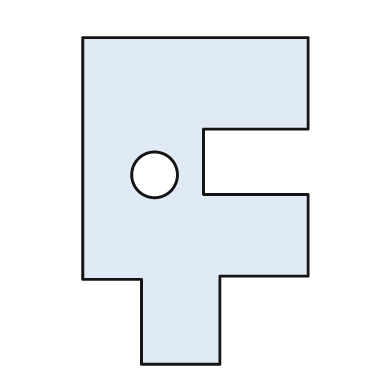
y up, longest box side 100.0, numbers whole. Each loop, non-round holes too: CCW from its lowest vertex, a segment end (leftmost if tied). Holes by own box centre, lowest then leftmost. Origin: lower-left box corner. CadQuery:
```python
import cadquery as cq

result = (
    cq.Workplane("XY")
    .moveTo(18.0, 0.0)
    .lineTo(42.0, 0.0)
    .lineTo(42.0, 27.0)
    .lineTo(69.0, 27.0)
    .lineTo(69.0, 52.0)
    .lineTo(37.0, 52.0)
    .lineTo(37.0, 72.0)
    .lineTo(69.0, 72.0)
    .lineTo(69.0, 100.0)
    .lineTo(0.0, 100.0)
    .lineTo(0.0, 26.0)
    .lineTo(18.0, 26.0)
    .close()
    .moveTo(22.0, 58.0)
    .circle(7.0)
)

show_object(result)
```